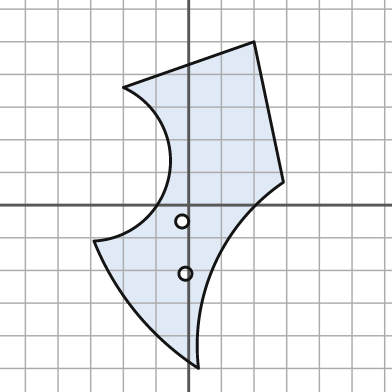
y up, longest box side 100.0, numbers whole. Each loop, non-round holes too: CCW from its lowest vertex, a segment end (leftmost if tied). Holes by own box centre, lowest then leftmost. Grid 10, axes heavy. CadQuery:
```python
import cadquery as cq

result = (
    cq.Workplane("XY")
    .moveTo(3.0, -50.0)
    .threePointArc((8.0, -18.0), (29.0, 7.0))
    .lineTo(20.0, 50.0)
    .lineTo(-20.0, 36.0)
    .threePointArc((-6.0, 9.0), (-29.0, -11.0))
    .threePointArc((-16.0, -33.0), (3.0, -50.0))
    .close()
    .moveTo(-1.0, -21.0)
    .circle(2.0)
    .moveTo(-2.0, -5.0)
    .circle(2.0)
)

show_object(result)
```